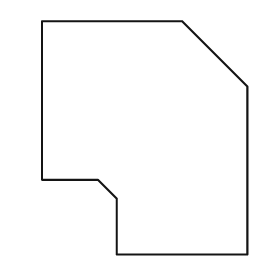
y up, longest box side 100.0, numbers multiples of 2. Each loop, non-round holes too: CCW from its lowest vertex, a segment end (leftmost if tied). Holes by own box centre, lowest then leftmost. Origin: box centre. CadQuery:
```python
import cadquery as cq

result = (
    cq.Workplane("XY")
    .moveTo(-12.0, -50.0)
    .lineTo(44.0, -50.0)
    .lineTo(44.0, 22.0)
    .lineTo(16.0, 50.0)
    .lineTo(-44.0, 50.0)
    .lineTo(-44.0, -18.0)
    .lineTo(-20.0, -18.0)
    .lineTo(-12.0, -26.0)
    .close()
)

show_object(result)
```